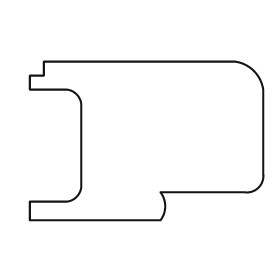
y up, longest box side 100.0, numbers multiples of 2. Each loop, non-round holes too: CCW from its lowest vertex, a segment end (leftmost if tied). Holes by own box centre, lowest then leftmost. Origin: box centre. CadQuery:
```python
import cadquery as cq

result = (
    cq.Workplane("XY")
    .moveTo(-50.0, -34.0)
    .lineTo(6.0, -34.0)
    .threePointArc((8.0, -28.0), (6.0, -22.0))
    .lineTo(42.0, -22.0)
    .threePointArc((48.0, -20.0), (50.0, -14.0))
    .lineTo(50.0, 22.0)
    .threePointArc((46.0, 30.0), (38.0, 34.0))
    .lineTo(-44.0, 34.0)
    .lineTo(-44.0, 28.0)
    .lineTo(-50.0, 28.0)
    .lineTo(-50.0, 22.0)
    .lineTo(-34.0, 22.0)
    .threePointArc((-30.0, 20.0), (-28.0, 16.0))
    .lineTo(-28.0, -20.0)
    .threePointArc((-30.0, -24.0), (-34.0, -26.0))
    .lineTo(-50.0, -26.0)
    .close()
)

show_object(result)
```